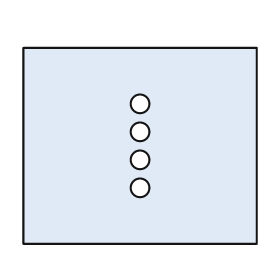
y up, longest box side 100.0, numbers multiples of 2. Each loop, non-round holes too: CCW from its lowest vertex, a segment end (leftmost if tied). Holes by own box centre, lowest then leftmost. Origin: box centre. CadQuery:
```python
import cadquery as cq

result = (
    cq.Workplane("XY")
    .moveTo(-50.0, -42.0)
    .lineTo(50.0, -42.0)
    .lineTo(50.0, 42.0)
    .lineTo(-50.0, 42.0)
    .close()
    .moveTo(0.0, -18.0)
    .circle(4.0)
    .moveTo(0.0, -6.0)
    .circle(4.0)
    .moveTo(0.0, 6.0)
    .circle(4.0)
    .moveTo(0.0, 18.0)
    .circle(4.0)
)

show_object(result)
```